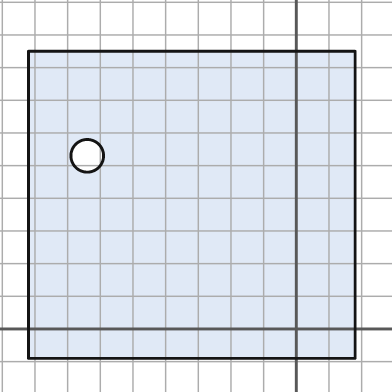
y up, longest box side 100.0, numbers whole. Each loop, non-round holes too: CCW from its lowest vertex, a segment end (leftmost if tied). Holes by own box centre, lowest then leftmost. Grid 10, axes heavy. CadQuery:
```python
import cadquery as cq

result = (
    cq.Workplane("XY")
    .moveTo(-82.0, -9.0)
    .lineTo(18.0, -9.0)
    .lineTo(18.0, 85.0)
    .lineTo(-82.0, 85.0)
    .close()
    .moveTo(-64.0, 53.0)
    .circle(5.0)
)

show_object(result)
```